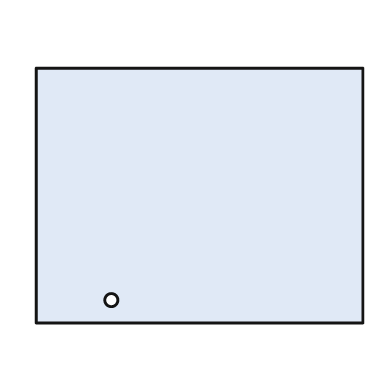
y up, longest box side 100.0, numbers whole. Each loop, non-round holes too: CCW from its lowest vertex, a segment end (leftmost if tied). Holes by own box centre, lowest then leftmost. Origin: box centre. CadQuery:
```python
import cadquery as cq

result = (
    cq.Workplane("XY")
    .moveTo(-50.0, -39.0)
    .lineTo(50.0, -39.0)
    .lineTo(50.0, 39.0)
    .lineTo(-50.0, 39.0)
    .close()
    .moveTo(-27.0, -32.0)
    .circle(2.0)
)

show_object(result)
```